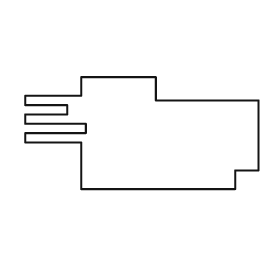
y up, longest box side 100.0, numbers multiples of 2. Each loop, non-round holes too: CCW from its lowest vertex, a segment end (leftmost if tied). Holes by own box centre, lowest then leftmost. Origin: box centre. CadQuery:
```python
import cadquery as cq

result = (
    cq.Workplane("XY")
    .moveTo(-26.0, -24.0)
    .lineTo(40.0, -24.0)
    .lineTo(40.0, -16.0)
    .lineTo(50.0, -16.0)
    .lineTo(50.0, 14.0)
    .lineTo(6.0, 14.0)
    .lineTo(6.0, 24.0)
    .lineTo(-26.0, 24.0)
    .lineTo(-26.0, 16.0)
    .lineTo(-50.0, 16.0)
    .lineTo(-50.0, 12.0)
    .lineTo(-32.0, 12.0)
    .lineTo(-32.0, 8.0)
    .lineTo(-50.0, 8.0)
    .lineTo(-50.0, 4.0)
    .lineTo(-24.0, 4.0)
    .lineTo(-24.0, 0.0)
    .lineTo(-50.0, 0.0)
    .lineTo(-50.0, -4.0)
    .lineTo(-26.0, -4.0)
    .close()
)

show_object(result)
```